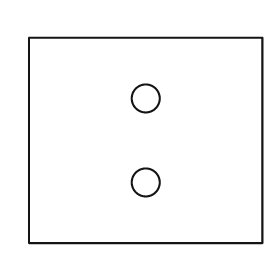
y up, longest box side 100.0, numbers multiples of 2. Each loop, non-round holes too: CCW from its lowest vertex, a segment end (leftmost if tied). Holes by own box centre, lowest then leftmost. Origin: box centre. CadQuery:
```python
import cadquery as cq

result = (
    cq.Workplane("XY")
    .moveTo(-50.0, -44.0)
    .lineTo(50.0, -44.0)
    .lineTo(50.0, 44.0)
    .lineTo(-50.0, 44.0)
    .close()
    .moveTo(0.0, -18.0)
    .circle(6.0)
    .moveTo(0.0, 18.0)
    .circle(6.0)
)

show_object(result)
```